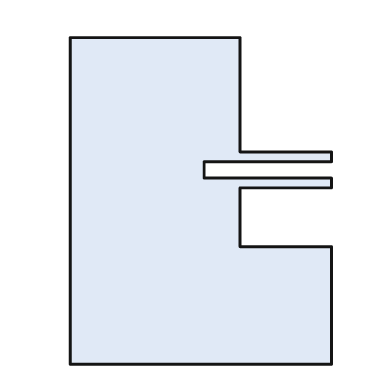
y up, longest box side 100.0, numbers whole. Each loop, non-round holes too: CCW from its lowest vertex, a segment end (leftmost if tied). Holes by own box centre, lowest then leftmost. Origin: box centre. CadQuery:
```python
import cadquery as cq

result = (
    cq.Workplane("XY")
    .moveTo(-40.0, -50.0)
    .lineTo(40.0, -50.0)
    .lineTo(40.0, -14.0)
    .lineTo(12.0, -14.0)
    .lineTo(12.0, 4.0)
    .lineTo(40.0, 4.0)
    .lineTo(40.0, 7.0)
    .lineTo(1.0, 7.0)
    .lineTo(1.0, 12.0)
    .lineTo(40.0, 12.0)
    .lineTo(40.0, 15.0)
    .lineTo(12.0, 15.0)
    .lineTo(12.0, 50.0)
    .lineTo(-40.0, 50.0)
    .close()
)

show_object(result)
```